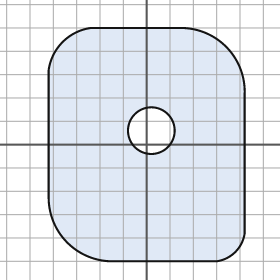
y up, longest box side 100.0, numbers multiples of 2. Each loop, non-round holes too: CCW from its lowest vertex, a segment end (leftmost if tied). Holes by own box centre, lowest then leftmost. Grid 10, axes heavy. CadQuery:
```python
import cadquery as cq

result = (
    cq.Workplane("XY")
    .moveTo(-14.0, -50.0)
    .lineTo(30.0, -50.0)
    .threePointArc((38.0, -46.0), (42.0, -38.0))
    .lineTo(42.0, 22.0)
    .threePointArc((34.0, 42.0), (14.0, 50.0))
    .lineTo(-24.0, 50.0)
    .threePointArc((-36.0, 44.0), (-42.0, 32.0))
    .lineTo(-42.0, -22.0)
    .threePointArc((-34.0, -42.0), (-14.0, -50.0))
    .close()
    .moveTo(2.0, 6.0)
    .circle(10.0)
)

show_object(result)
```